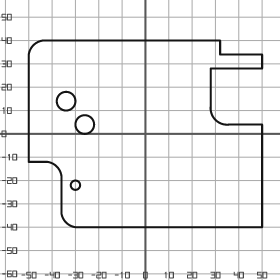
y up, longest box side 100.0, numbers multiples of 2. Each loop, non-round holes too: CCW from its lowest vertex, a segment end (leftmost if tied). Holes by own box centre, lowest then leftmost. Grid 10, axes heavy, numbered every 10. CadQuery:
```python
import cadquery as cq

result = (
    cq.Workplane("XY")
    .moveTo(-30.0, -40.0)
    .lineTo(50.0, -40.0)
    .lineTo(50.0, 4.0)
    .lineTo(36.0, 4.0)
    .threePointArc((30.0, 6.0), (28.0, 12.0))
    .lineTo(28.0, 28.0)
    .lineTo(50.0, 28.0)
    .lineTo(50.0, 34.0)
    .lineTo(32.0, 34.0)
    .lineTo(32.0, 40.0)
    .lineTo(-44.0, 40.0)
    .threePointArc((-48.0, 38.0), (-50.0, 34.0))
    .lineTo(-50.0, -12.0)
    .lineTo(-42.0, -12.0)
    .threePointArc((-38.0, -14.0), (-36.0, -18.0))
    .lineTo(-36.0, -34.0)
    .threePointArc((-34.0, -38.0), (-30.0, -40.0))
    .close()
    .moveTo(-30.0, -22.0)
    .circle(2.0)
    .moveTo(-26.0, 4.0)
    .circle(4.0)
    .moveTo(-34.0, 14.0)
    .circle(4.0)
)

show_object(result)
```